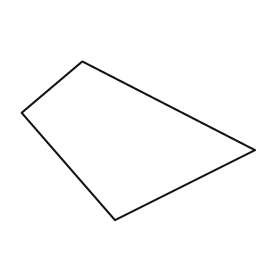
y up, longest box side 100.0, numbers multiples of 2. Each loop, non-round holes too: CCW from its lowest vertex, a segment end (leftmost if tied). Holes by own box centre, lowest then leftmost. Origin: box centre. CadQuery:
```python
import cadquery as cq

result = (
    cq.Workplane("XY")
    .moveTo(-10.0, -34.0)
    .lineTo(50.0, -4.0)
    .lineTo(-24.0, 34.0)
    .lineTo(-50.0, 12.0)
    .close()
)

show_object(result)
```